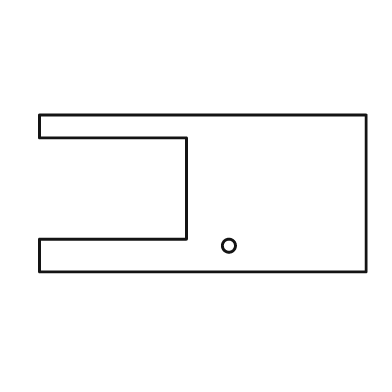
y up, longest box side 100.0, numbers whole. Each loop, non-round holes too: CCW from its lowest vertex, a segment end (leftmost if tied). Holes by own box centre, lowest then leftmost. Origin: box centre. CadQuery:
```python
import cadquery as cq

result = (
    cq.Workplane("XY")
    .moveTo(-50.0, -24.0)
    .lineTo(50.0, -24.0)
    .lineTo(50.0, 24.0)
    .lineTo(-50.0, 24.0)
    .lineTo(-50.0, 17.0)
    .lineTo(-5.0, 17.0)
    .lineTo(-5.0, -14.0)
    .lineTo(-50.0, -14.0)
    .close()
    .moveTo(8.0, -16.0)
    .circle(2.0)
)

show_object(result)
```